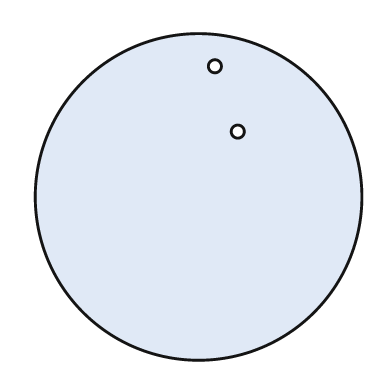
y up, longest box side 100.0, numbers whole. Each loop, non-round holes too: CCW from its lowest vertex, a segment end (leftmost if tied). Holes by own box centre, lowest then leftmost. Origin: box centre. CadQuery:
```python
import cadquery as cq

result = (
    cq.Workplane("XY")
    .moveTo(0.0, 0.0)
    .circle(50.0)
    .moveTo(12.0, 20.0)
    .circle(2.0)
    .moveTo(5.0, 40.0)
    .circle(2.0)
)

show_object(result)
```